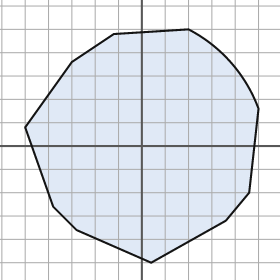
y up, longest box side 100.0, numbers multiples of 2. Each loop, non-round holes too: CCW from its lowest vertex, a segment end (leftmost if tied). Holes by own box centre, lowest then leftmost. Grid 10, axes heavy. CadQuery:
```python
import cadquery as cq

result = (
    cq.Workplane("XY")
    .moveTo(4.0, -50.0)
    .lineTo(36.0, -32.0)
    .lineTo(46.0, -20.0)
    .lineTo(50.0, 16.0)
    .threePointArc((38.0, 36.0), (20.0, 50.0))
    .lineTo(-12.0, 48.0)
    .lineTo(-30.0, 36.0)
    .lineTo(-50.0, 8.0)
    .lineTo(-38.0, -26.0)
    .lineTo(-28.0, -36.0)
    .close()
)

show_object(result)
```